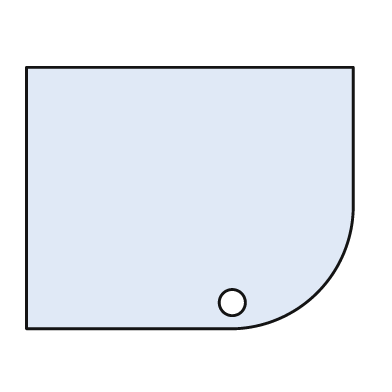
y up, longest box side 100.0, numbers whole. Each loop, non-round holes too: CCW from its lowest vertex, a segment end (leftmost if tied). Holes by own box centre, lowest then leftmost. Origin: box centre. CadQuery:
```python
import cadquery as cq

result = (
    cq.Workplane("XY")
    .moveTo(-50.0, -40.0)
    .lineTo(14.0, -40.0)
    .threePointArc((39.0, -29.0), (50.0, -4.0))
    .lineTo(50.0, 40.0)
    .lineTo(-50.0, 40.0)
    .close()
    .moveTo(13.0, -32.0)
    .circle(4.0)
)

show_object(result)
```